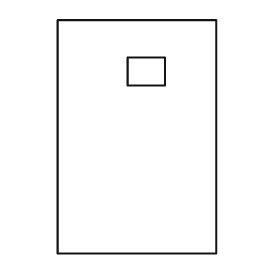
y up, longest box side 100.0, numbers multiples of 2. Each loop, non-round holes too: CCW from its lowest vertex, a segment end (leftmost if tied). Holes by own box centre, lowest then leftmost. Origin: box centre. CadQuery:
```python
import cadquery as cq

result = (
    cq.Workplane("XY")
    .moveTo(-34.0, -50.0)
    .lineTo(34.0, -50.0)
    .lineTo(34.0, 50.0)
    .lineTo(-34.0, 50.0)
    .close()
    .moveTo(-4.0, 22.0)
    .lineTo(12.0, 22.0)
    .lineTo(12.0, 34.0)
    .lineTo(-4.0, 34.0)
    .close()
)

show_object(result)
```